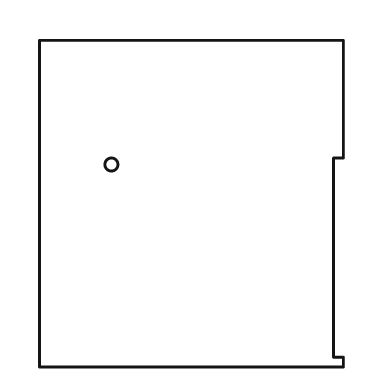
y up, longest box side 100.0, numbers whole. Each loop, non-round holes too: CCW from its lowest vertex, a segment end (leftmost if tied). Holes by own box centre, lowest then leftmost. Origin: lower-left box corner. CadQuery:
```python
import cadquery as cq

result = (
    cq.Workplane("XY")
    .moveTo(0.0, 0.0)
    .lineTo(93.0, 0.0)
    .lineTo(93.0, 3.0)
    .lineTo(90.0, 3.0)
    .lineTo(90.0, 64.0)
    .lineTo(93.0, 64.0)
    .lineTo(93.0, 100.0)
    .lineTo(0.0, 100.0)
    .close()
    .moveTo(22.0, 62.0)
    .circle(2.0)
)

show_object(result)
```